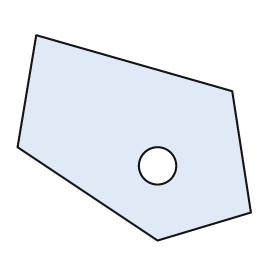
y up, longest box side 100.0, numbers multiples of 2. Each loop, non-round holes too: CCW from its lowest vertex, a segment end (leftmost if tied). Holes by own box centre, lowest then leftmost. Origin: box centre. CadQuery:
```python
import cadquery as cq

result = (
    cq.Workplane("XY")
    .moveTo(10.0, -44.0)
    .lineTo(50.0, -32.0)
    .lineTo(42.0, 20.0)
    .lineTo(-42.0, 44.0)
    .lineTo(-50.0, -4.0)
    .close()
    .moveTo(10.0, -12.0)
    .circle(8.0)
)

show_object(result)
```